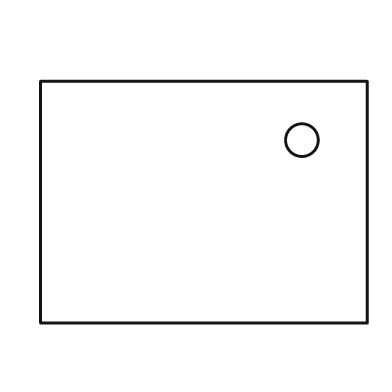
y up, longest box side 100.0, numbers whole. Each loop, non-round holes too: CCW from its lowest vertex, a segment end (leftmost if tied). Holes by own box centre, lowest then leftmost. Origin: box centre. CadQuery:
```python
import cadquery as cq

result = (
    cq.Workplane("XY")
    .moveTo(-50.0, -37.0)
    .lineTo(50.0, -37.0)
    .lineTo(50.0, 37.0)
    .lineTo(-50.0, 37.0)
    .close()
    .moveTo(30.0, 19.0)
    .circle(5.0)
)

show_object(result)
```